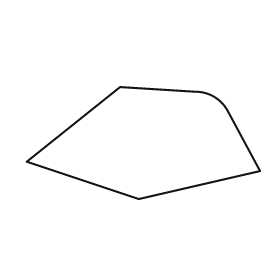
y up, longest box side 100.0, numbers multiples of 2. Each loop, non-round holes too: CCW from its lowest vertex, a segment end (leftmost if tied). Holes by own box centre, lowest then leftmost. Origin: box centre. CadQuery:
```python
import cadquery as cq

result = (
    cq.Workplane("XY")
    .moveTo(-2.0, -24.0)
    .lineTo(50.0, -12.0)
    .lineTo(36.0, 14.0)
    .threePointArc((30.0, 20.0), (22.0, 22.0))
    .lineTo(-10.0, 24.0)
    .lineTo(-50.0, -8.0)
    .close()
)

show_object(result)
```